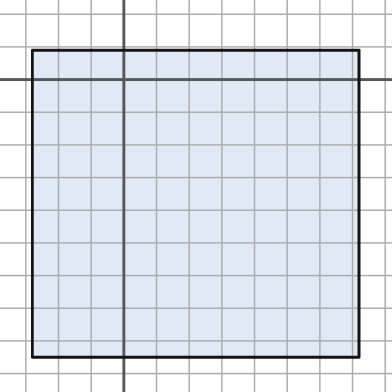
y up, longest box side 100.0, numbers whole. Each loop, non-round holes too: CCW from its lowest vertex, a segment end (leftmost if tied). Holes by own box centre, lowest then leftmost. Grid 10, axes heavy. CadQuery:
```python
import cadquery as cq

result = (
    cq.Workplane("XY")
    .moveTo(-28.0, -85.0)
    .lineTo(72.0, -85.0)
    .lineTo(72.0, 9.0)
    .lineTo(-28.0, 9.0)
    .close()
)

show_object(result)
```